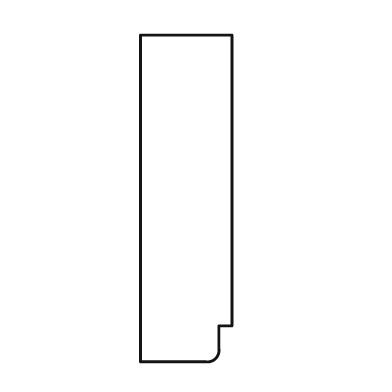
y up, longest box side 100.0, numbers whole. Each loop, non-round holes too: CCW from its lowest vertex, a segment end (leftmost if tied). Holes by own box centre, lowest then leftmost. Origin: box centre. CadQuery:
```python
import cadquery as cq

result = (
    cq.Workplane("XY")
    .moveTo(-14.0, -50.0)
    .lineTo(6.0, -50.0)
    .threePointArc((9.0, -49.0), (10.0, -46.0))
    .lineTo(10.0, -39.0)
    .lineTo(14.0, -39.0)
    .lineTo(14.0, 50.0)
    .lineTo(-14.0, 50.0)
    .close()
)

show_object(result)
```